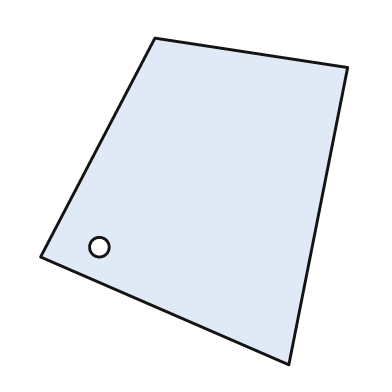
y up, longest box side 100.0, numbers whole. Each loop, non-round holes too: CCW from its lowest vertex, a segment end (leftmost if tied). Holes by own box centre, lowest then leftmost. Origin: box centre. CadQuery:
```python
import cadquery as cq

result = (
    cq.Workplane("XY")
    .moveTo(29.0, -50.0)
    .lineTo(47.0, 41.0)
    .lineTo(-12.0, 50.0)
    .lineTo(-47.0, -17.0)
    .close()
    .moveTo(-29.0, -14.0)
    .circle(3.0)
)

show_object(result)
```